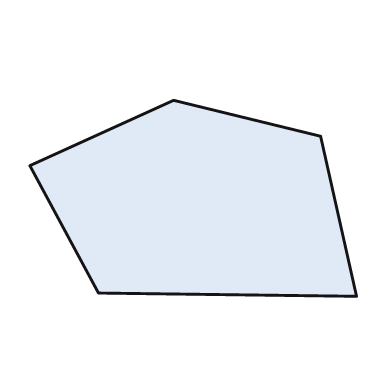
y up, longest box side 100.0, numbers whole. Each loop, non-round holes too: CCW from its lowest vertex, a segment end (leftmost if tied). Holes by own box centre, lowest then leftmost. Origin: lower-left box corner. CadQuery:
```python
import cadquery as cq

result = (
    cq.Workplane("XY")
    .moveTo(100.0, 0.0)
    .lineTo(89.0, 49.0)
    .lineTo(44.0, 60.0)
    .lineTo(0.0, 40.0)
    .lineTo(21.0, 1.0)
    .close()
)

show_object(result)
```